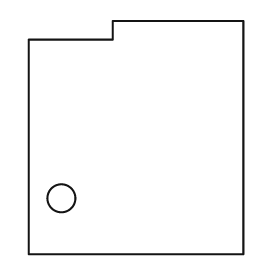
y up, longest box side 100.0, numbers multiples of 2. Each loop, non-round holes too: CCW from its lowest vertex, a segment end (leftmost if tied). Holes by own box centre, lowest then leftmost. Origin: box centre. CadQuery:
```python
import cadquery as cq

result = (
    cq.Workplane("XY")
    .moveTo(-46.0, -50.0)
    .lineTo(46.0, -50.0)
    .lineTo(46.0, 50.0)
    .lineTo(-10.0, 50.0)
    .lineTo(-10.0, 42.0)
    .lineTo(-46.0, 42.0)
    .close()
    .moveTo(-32.0, -26.0)
    .circle(6.0)
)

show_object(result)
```